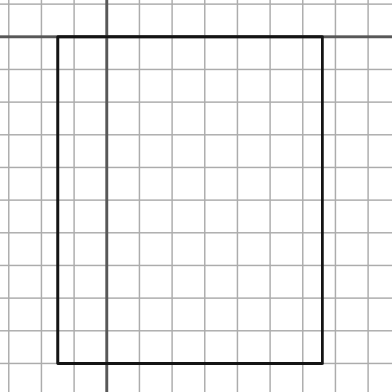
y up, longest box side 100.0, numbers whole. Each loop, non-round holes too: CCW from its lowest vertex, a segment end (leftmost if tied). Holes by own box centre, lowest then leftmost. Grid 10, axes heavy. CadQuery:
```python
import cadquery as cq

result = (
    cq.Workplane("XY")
    .moveTo(-15.0, -100.0)
    .lineTo(66.0, -100.0)
    .lineTo(66.0, 0.0)
    .lineTo(-15.0, 0.0)
    .close()
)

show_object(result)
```